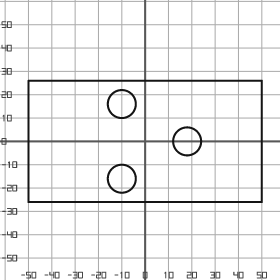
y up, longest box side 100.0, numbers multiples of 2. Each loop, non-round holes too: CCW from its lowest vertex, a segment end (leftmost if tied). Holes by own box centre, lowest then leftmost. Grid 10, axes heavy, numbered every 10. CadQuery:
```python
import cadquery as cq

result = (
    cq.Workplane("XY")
    .moveTo(-50.0, -26.0)
    .lineTo(50.0, -26.0)
    .lineTo(50.0, 26.0)
    .lineTo(-50.0, 26.0)
    .close()
    .moveTo(-10.0, -16.0)
    .circle(6.0)
    .moveTo(18.0, 0.0)
    .circle(6.0)
    .moveTo(-10.0, 16.0)
    .circle(6.0)
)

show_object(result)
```